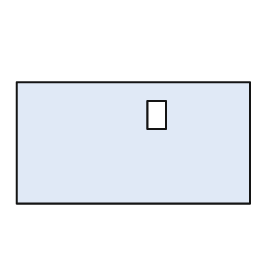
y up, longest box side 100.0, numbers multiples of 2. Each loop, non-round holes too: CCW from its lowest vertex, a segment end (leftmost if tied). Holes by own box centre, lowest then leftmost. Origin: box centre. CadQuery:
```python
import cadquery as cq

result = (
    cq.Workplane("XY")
    .moveTo(-50.0, -26.0)
    .lineTo(50.0, -26.0)
    .lineTo(50.0, 26.0)
    .lineTo(-50.0, 26.0)
    .close()
    .moveTo(6.0, 6.0)
    .lineTo(14.0, 6.0)
    .lineTo(14.0, 18.0)
    .lineTo(6.0, 18.0)
    .close()
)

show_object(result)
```